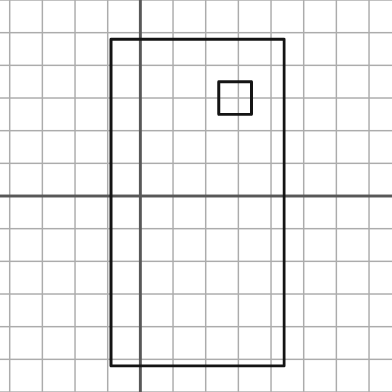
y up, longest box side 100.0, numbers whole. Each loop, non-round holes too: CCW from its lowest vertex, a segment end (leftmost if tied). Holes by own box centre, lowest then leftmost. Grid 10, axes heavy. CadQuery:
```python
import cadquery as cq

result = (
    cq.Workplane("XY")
    .moveTo(-9.0, -52.0)
    .lineTo(44.0, -52.0)
    .lineTo(44.0, 48.0)
    .lineTo(-9.0, 48.0)
    .close()
    .moveTo(24.0, 25.0)
    .lineTo(34.0, 25.0)
    .lineTo(34.0, 35.0)
    .lineTo(24.0, 35.0)
    .close()
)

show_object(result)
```